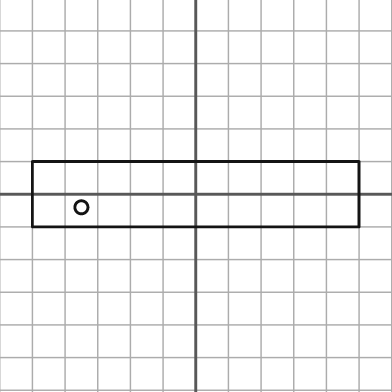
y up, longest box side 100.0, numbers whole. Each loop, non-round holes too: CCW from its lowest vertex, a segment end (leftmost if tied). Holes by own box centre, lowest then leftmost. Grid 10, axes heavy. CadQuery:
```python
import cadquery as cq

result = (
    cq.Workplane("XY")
    .moveTo(-50.0, -10.0)
    .lineTo(50.0, -10.0)
    .lineTo(50.0, 10.0)
    .lineTo(-50.0, 10.0)
    .close()
    .moveTo(-35.0, -4.0)
    .circle(2.0)
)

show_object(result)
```